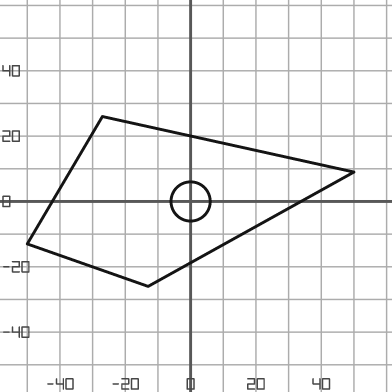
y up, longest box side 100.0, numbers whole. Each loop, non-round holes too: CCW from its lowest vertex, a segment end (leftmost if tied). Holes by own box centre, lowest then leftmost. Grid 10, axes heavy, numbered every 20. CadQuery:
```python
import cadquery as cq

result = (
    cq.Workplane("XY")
    .moveTo(-13.0, -26.0)
    .lineTo(50.0, 9.0)
    .lineTo(-27.0, 26.0)
    .lineTo(-50.0, -13.0)
    .close()
    .moveTo(0.0, 0.0)
    .circle(6.0)
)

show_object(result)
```